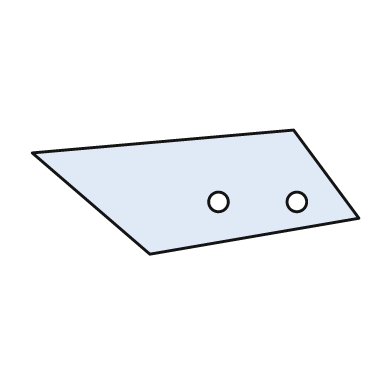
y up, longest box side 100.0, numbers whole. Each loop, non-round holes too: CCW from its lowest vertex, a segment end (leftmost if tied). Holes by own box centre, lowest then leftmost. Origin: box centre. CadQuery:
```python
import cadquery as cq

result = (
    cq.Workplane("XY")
    .moveTo(-14.0, -19.0)
    .lineTo(50.0, -8.0)
    .lineTo(30.0, 19.0)
    .lineTo(-50.0, 12.0)
    .close()
    .moveTo(7.0, -3.0)
    .circle(3.0)
    .moveTo(31.0, -3.0)
    .circle(3.0)
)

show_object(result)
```